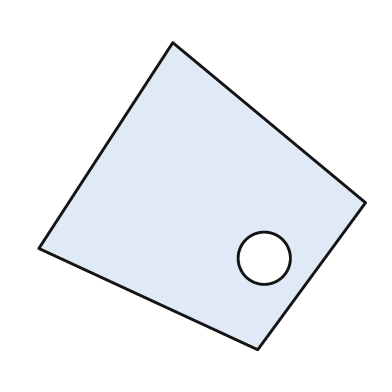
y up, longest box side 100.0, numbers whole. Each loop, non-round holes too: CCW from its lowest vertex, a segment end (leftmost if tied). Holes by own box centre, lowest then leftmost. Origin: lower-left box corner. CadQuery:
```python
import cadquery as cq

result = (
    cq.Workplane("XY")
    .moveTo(67.0, 0.0)
    .lineTo(100.0, 45.0)
    .lineTo(41.0, 94.0)
    .lineTo(0.0, 31.0)
    .close()
    .moveTo(69.0, 28.0)
    .circle(8.0)
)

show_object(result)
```